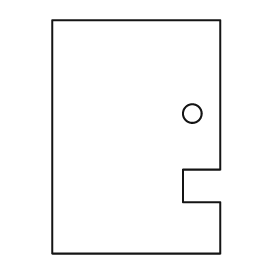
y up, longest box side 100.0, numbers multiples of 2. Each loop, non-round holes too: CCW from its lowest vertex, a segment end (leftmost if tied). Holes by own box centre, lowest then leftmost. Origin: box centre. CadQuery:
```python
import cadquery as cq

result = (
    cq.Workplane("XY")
    .moveTo(-36.0, -50.0)
    .lineTo(36.0, -50.0)
    .lineTo(36.0, -28.0)
    .lineTo(20.0, -28.0)
    .lineTo(20.0, -14.0)
    .lineTo(36.0, -14.0)
    .lineTo(36.0, 50.0)
    .lineTo(-36.0, 50.0)
    .close()
    .moveTo(24.0, 10.0)
    .circle(4.0)
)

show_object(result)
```